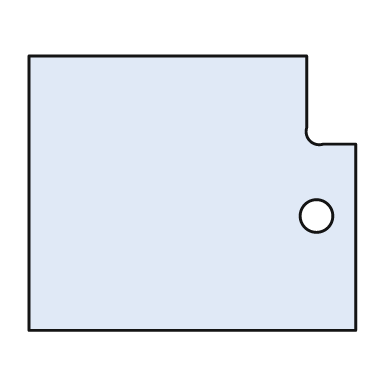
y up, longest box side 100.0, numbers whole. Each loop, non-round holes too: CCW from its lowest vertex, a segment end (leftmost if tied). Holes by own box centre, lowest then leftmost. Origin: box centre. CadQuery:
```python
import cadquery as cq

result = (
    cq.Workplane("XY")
    .moveTo(-50.0, -42.0)
    .lineTo(50.0, -42.0)
    .lineTo(50.0, 15.0)
    .lineTo(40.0, 15.0)
    .threePointArc((36.0, 16.0), (35.0, 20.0))
    .lineTo(35.0, 42.0)
    .lineTo(-50.0, 42.0)
    .close()
    .moveTo(38.0, -7.0)
    .circle(5.0)
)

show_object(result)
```